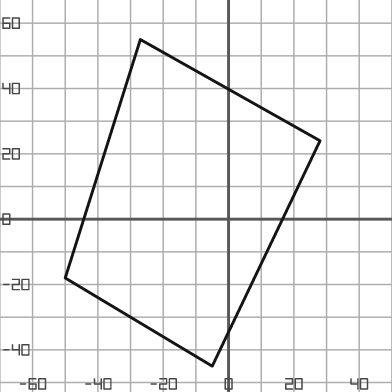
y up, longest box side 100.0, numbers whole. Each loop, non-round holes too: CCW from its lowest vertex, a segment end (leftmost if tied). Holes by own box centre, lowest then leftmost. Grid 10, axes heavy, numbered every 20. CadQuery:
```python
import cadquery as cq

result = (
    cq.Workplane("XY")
    .moveTo(-5.0, -45.0)
    .lineTo(28.0, 24.0)
    .lineTo(-27.0, 55.0)
    .lineTo(-50.0, -18.0)
    .close()
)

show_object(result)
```